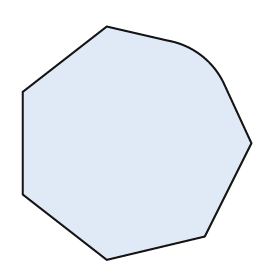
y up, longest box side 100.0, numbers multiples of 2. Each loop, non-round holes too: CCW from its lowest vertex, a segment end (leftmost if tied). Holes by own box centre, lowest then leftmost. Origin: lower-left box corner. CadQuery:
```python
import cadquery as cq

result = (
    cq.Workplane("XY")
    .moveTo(36.0, 0.0)
    .lineTo(78.0, 10.0)
    .lineTo(98.0, 50.0)
    .lineTo(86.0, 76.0)
    .threePointArc((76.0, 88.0), (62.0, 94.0))
    .lineTo(36.0, 100.0)
    .lineTo(0.0, 72.0)
    .lineTo(0.0, 28.0)
    .close()
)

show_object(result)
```